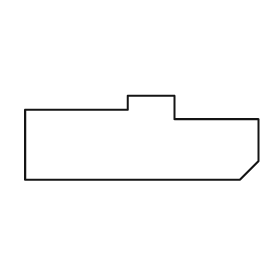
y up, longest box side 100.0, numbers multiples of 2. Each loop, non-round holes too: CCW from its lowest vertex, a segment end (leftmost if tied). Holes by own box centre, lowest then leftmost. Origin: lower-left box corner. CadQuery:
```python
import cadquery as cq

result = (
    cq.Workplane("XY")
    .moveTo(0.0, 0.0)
    .lineTo(92.0, 0.0)
    .lineTo(100.0, 8.0)
    .lineTo(100.0, 26.0)
    .lineTo(64.0, 26.0)
    .lineTo(64.0, 36.0)
    .lineTo(44.0, 36.0)
    .lineTo(44.0, 30.0)
    .lineTo(0.0, 30.0)
    .close()
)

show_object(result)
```